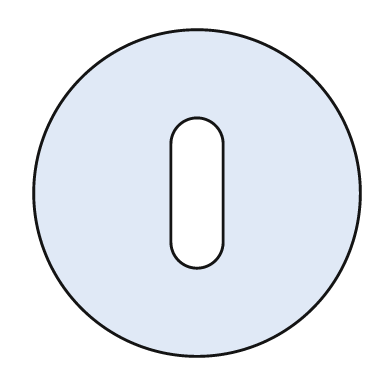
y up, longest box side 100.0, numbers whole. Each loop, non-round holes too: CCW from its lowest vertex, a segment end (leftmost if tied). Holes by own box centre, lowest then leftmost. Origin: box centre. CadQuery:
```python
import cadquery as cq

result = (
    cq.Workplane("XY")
    .moveTo(0.0, 0.0)
    .circle(50.0)
    .moveTo(-8.0, -15.0)
    .threePointArc((0.0, -23.0), (8.0, -15.0))
    .lineTo(8.0, 15.0)
    .threePointArc((0.0, 23.0), (-8.0, 15.0))
    .close()
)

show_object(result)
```